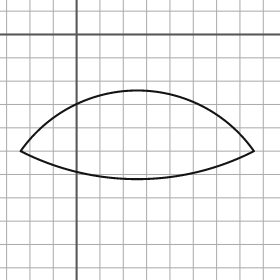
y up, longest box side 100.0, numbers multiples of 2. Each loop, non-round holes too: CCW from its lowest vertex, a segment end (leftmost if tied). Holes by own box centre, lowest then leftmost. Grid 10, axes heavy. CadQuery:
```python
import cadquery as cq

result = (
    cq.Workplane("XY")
    .moveTo(-24.0, -50.0)
    .threePointArc((26.0, -62.0), (76.0, -50.0))
    .threePointArc((26.0, -24.0), (-24.0, -50.0))
    .close()
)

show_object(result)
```